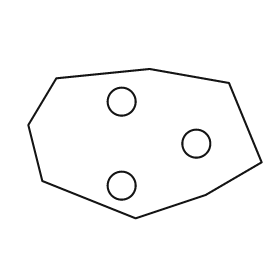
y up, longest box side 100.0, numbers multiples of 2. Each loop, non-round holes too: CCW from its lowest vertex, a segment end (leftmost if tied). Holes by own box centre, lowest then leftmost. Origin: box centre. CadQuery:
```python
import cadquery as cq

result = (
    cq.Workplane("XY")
    .moveTo(-4.0, -32.0)
    .lineTo(26.0, -22.0)
    .lineTo(50.0, -8.0)
    .lineTo(36.0, 26.0)
    .lineTo(2.0, 32.0)
    .lineTo(-38.0, 28.0)
    .lineTo(-50.0, 8.0)
    .lineTo(-44.0, -16.0)
    .close()
    .moveTo(-10.0, -18.0)
    .circle(6.0)
    .moveTo(22.0, 0.0)
    .circle(6.0)
    .moveTo(-10.0, 18.0)
    .circle(6.0)
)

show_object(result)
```